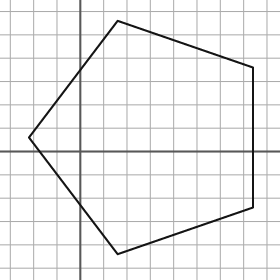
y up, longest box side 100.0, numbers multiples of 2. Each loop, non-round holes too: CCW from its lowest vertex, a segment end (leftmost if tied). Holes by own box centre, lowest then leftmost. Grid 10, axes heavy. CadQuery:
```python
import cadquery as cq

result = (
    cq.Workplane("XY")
    .moveTo(16.0, -44.0)
    .lineTo(74.0, -24.0)
    .lineTo(74.0, 36.0)
    .lineTo(16.0, 56.0)
    .lineTo(-22.0, 6.0)
    .close()
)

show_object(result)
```